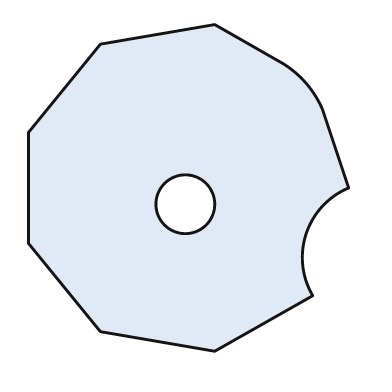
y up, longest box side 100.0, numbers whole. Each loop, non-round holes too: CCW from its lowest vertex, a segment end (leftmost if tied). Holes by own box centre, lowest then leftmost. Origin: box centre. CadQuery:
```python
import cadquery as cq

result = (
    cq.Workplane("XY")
    .moveTo(8.0, -50.0)
    .lineTo(38.0, -33.0)
    .threePointArc((36.0, -14.0), (49.0, 0.0))
    .lineTo(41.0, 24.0)
    .threePointArc((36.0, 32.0), (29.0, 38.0))
    .lineTo(8.0, 50.0)
    .lineTo(-27.0, 44.0)
    .lineTo(-49.0, 17.0)
    .lineTo(-49.0, -17.0)
    .lineTo(-27.0, -44.0)
    .close()
    .moveTo(-1.0, -5.0)
    .circle(9.0)
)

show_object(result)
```